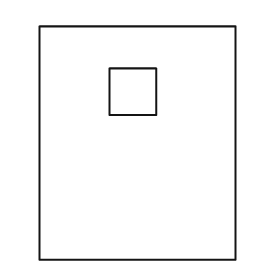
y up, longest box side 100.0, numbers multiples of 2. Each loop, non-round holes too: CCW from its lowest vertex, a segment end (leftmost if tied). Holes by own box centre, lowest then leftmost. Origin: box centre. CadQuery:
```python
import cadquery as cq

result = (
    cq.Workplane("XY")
    .moveTo(-42.0, -50.0)
    .lineTo(42.0, -50.0)
    .lineTo(42.0, 50.0)
    .lineTo(-42.0, 50.0)
    .close()
    .moveTo(-12.0, 12.0)
    .lineTo(8.0, 12.0)
    .lineTo(8.0, 32.0)
    .lineTo(-12.0, 32.0)
    .close()
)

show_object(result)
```